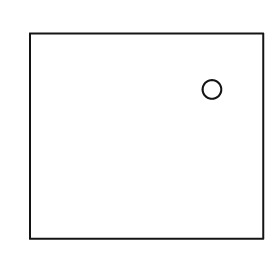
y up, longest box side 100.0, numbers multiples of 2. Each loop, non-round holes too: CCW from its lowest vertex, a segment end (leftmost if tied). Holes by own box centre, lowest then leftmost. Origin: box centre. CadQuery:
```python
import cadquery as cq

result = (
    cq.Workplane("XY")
    .moveTo(-50.0, -44.0)
    .lineTo(50.0, -44.0)
    .lineTo(50.0, 44.0)
    .lineTo(-50.0, 44.0)
    .close()
    .moveTo(28.0, 20.0)
    .circle(4.0)
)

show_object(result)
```